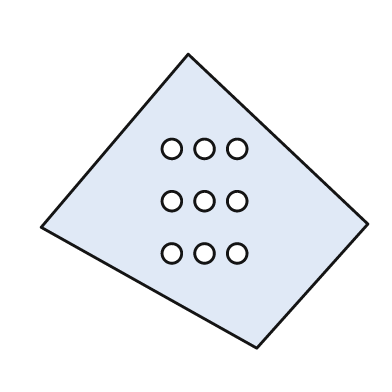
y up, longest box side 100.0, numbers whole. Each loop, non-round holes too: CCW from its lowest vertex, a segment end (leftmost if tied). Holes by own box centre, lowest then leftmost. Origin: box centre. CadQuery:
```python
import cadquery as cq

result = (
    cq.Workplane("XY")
    .moveTo(16.0, -45.0)
    .lineTo(50.0, -7.0)
    .lineTo(-5.0, 45.0)
    .lineTo(-50.0, -8.0)
    .close()
    .moveTo(-10.0, -16.0)
    .circle(3.0)
    .moveTo(0.0, -16.0)
    .circle(3.0)
    .moveTo(10.0, -16.0)
    .circle(3.0)
    .moveTo(-10.0, 0.0)
    .circle(3.0)
    .moveTo(0.0, 0.0)
    .circle(3.0)
    .moveTo(10.0, 0.0)
    .circle(3.0)
    .moveTo(-10.0, 16.0)
    .circle(3.0)
    .moveTo(0.0, 16.0)
    .circle(3.0)
    .moveTo(10.0, 16.0)
    .circle(3.0)
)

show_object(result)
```